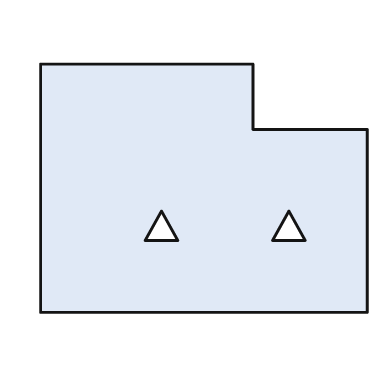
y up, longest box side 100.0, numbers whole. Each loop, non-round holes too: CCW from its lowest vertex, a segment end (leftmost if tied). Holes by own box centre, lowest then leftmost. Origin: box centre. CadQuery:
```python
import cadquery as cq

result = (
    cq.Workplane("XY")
    .moveTo(-50.0, -38.0)
    .lineTo(50.0, -38.0)
    .lineTo(50.0, 18.0)
    .lineTo(15.0, 18.0)
    .lineTo(15.0, 38.0)
    .lineTo(-50.0, 38.0)
    .close()
    .moveTo(-18.0, -16.0)
    .lineTo(-8.0, -16.0)
    .lineTo(-13.0, -7.0)
    .close()
    .moveTo(21.0, -16.0)
    .lineTo(31.0, -16.0)
    .lineTo(26.0, -7.0)
    .close()
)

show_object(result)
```